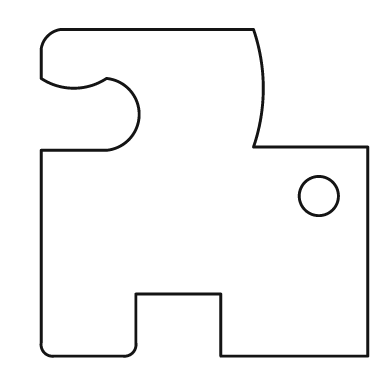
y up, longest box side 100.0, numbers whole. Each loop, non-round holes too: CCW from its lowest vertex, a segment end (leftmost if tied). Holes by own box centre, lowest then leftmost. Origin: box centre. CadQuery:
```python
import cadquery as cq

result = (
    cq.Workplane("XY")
    .moveTo(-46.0, -50.0)
    .lineTo(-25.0, -50.0)
    .threePointArc((-22.0, -49.0), (-21.0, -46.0))
    .lineTo(-21.0, -31.0)
    .lineTo(5.0, -31.0)
    .lineTo(5.0, -50.0)
    .lineTo(50.0, -50.0)
    .lineTo(50.0, 14.0)
    .lineTo(15.0, 14.0)
    .threePointArc((18.0, 32.0), (15.0, 50.0))
    .lineTo(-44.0, 50.0)
    .threePointArc((-48.0, 48.0), (-50.0, 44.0))
    .lineTo(-50.0, 35.0)
    .threePointArc((-40.0, 32.0), (-30.0, 35.0))
    .threePointArc((-20.0, 24.0), (-30.0, 13.0))
    .lineTo(-50.0, 13.0)
    .lineTo(-50.0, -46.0)
    .threePointArc((-49.0, -49.0), (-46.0, -50.0))
    .close()
    .moveTo(35.0, -1.0)
    .circle(6.0)
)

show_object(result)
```